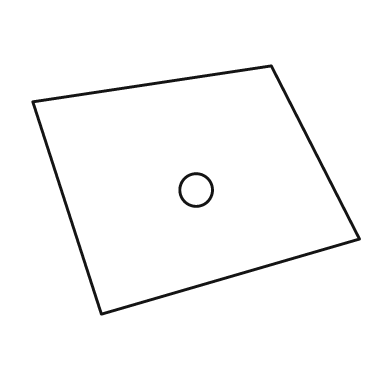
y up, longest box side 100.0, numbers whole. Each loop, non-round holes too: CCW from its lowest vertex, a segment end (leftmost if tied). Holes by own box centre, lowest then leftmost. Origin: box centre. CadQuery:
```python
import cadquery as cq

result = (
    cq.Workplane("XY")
    .moveTo(-29.0, -38.0)
    .lineTo(50.0, -15.0)
    .lineTo(23.0, 38.0)
    .lineTo(-50.0, 27.0)
    .close()
    .moveTo(0.0, 0.0)
    .circle(5.0)
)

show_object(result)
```